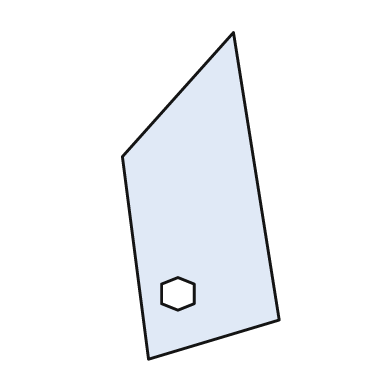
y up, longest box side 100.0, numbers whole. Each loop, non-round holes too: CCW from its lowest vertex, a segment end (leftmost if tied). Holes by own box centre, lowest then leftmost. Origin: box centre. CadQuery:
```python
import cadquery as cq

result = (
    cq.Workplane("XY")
    .moveTo(-16.0, -50.0)
    .lineTo(24.0, -38.0)
    .lineTo(10.0, 50.0)
    .lineTo(-24.0, 12.0)
    .close()
    .moveTo(-7.0, -35.0)
    .lineTo(-2.0, -33.0)
    .lineTo(-2.0, -27.0)
    .lineTo(-7.0, -25.0)
    .lineTo(-12.0, -27.0)
    .lineTo(-12.0, -33.0)
    .close()
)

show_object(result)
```